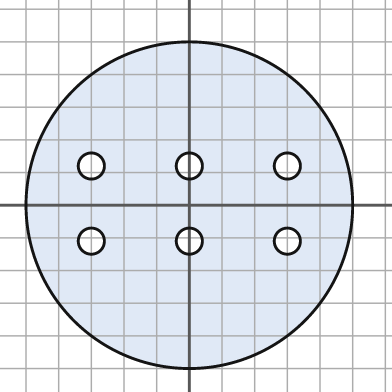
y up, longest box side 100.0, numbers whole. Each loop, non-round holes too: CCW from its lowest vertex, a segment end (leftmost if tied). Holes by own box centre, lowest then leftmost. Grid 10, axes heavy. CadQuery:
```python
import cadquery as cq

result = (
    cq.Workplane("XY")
    .moveTo(0.0, 0.0)
    .circle(50.0)
    .moveTo(-30.0, -11.0)
    .circle(4.0)
    .moveTo(0.0, -11.0)
    .circle(4.0)
    .moveTo(30.0, -11.0)
    .circle(4.0)
    .moveTo(-30.0, 12.0)
    .circle(4.0)
    .moveTo(0.0, 12.0)
    .circle(4.0)
    .moveTo(30.0, 12.0)
    .circle(4.0)
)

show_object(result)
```